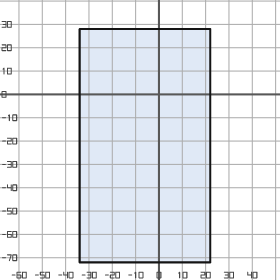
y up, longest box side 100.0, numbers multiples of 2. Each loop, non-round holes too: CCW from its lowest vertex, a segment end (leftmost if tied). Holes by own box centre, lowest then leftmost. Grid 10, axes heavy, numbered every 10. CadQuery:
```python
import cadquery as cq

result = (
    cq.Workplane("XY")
    .moveTo(-34.0, -72.0)
    .lineTo(22.0, -72.0)
    .lineTo(22.0, 28.0)
    .lineTo(-34.0, 28.0)
    .close()
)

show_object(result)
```